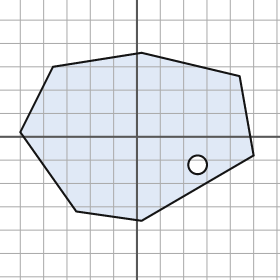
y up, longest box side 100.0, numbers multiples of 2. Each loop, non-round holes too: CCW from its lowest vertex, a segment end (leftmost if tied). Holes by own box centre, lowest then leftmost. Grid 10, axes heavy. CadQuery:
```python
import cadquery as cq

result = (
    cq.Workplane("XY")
    .moveTo(2.0, -36.0)
    .lineTo(50.0, -8.0)
    .lineTo(44.0, 26.0)
    .lineTo(2.0, 36.0)
    .lineTo(-36.0, 30.0)
    .lineTo(-50.0, 2.0)
    .lineTo(-26.0, -32.0)
    .close()
    .moveTo(26.0, -12.0)
    .circle(4.0)
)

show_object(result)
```